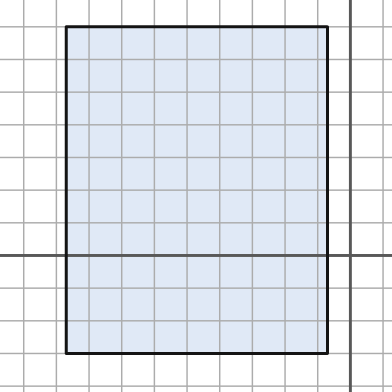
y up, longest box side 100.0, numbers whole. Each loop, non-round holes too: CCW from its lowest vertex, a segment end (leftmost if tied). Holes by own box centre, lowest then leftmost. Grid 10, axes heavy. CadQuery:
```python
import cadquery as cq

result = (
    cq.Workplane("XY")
    .moveTo(-87.0, -30.0)
    .lineTo(-7.0, -30.0)
    .lineTo(-7.0, 70.0)
    .lineTo(-87.0, 70.0)
    .close()
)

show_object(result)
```